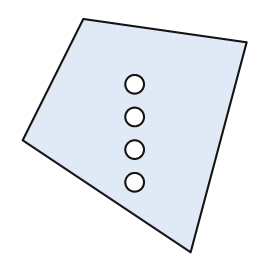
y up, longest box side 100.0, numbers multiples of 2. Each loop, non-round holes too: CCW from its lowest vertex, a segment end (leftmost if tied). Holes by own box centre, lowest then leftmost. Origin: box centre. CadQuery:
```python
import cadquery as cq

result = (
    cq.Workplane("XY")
    .moveTo(24.0, -50.0)
    .lineTo(48.0, 40.0)
    .lineTo(-22.0, 50.0)
    .lineTo(-48.0, -2.0)
    .close()
    .moveTo(0.0, -20.0)
    .circle(4.0)
    .moveTo(0.0, -6.0)
    .circle(4.0)
    .moveTo(0.0, 8.0)
    .circle(4.0)
    .moveTo(0.0, 22.0)
    .circle(4.0)
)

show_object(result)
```